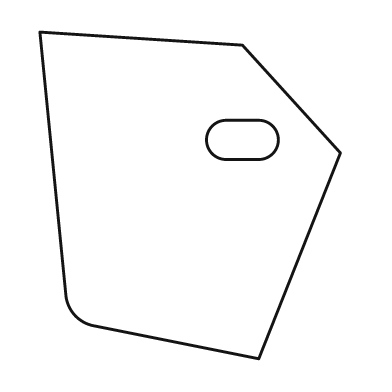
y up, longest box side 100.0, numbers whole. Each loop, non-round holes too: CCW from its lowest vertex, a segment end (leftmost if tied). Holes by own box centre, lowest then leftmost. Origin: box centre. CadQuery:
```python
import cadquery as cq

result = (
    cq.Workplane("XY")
    .moveTo(21.0, -50.0)
    .lineTo(46.0, 13.0)
    .lineTo(16.0, 46.0)
    .lineTo(-46.0, 50.0)
    .lineTo(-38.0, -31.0)
    .threePointArc((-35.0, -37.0), (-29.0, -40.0))
    .close()
    .moveTo(11.0, 11.0)
    .lineTo(21.0, 11.0)
    .threePointArc((27.0, 17.0), (21.0, 23.0))
    .lineTo(11.0, 23.0)
    .threePointArc((5.0, 17.0), (11.0, 11.0))
    .close()
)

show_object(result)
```